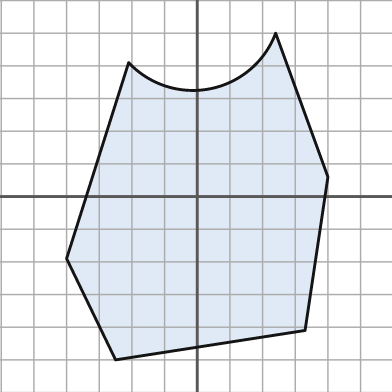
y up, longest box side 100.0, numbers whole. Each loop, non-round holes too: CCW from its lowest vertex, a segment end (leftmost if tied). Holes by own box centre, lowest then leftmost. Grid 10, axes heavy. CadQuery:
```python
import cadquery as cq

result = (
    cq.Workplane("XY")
    .moveTo(-25.0, -50.0)
    .lineTo(33.0, -41.0)
    .lineTo(40.0, 6.0)
    .lineTo(24.0, 50.0)
    .threePointArc((4.0, 33.0), (-21.0, 41.0))
    .lineTo(-40.0, -19.0)
    .close()
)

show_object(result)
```